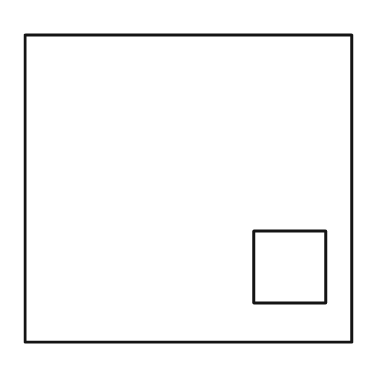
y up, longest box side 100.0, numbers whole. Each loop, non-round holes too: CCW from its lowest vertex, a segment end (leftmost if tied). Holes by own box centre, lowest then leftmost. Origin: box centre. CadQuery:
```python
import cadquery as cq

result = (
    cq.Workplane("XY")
    .moveTo(-50.0, -47.0)
    .lineTo(50.0, -47.0)
    .lineTo(50.0, 47.0)
    .lineTo(-50.0, 47.0)
    .close()
    .moveTo(20.0, -35.0)
    .lineTo(42.0, -35.0)
    .lineTo(42.0, -13.0)
    .lineTo(20.0, -13.0)
    .close()
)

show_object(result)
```